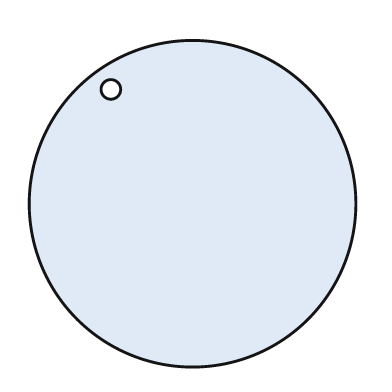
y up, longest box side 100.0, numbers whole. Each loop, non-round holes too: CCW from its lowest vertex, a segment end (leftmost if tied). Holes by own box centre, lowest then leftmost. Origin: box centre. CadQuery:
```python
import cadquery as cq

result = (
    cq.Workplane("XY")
    .moveTo(0.0, 0.0)
    .circle(50.0)
    .moveTo(-25.0, 35.0)
    .circle(3.0)
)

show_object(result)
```